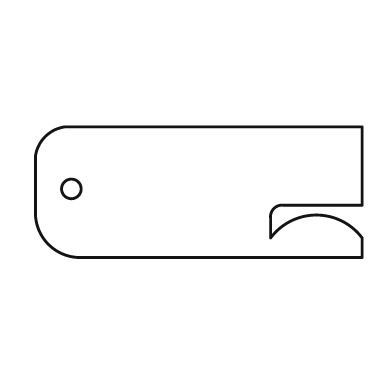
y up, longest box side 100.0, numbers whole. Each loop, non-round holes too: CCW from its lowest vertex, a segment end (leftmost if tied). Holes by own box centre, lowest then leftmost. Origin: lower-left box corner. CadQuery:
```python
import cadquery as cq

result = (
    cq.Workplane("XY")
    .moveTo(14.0, 0.0)
    .lineTo(100.0, 0.0)
    .lineTo(100.0, 6.0)
    .threePointArc((86.0, 13.0), (72.0, 6.0))
    .lineTo(72.0, 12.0)
    .threePointArc((73.0, 15.0), (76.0, 16.0))
    .lineTo(100.0, 16.0)
    .lineTo(100.0, 40.0)
    .lineTo(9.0, 40.0)
    .threePointArc((3.0, 37.0), (0.0, 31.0))
    .lineTo(0.0, 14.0)
    .threePointArc((4.0, 4.0), (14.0, 0.0))
    .close()
    .moveTo(11.0, 21.0)
    .circle(3.0)
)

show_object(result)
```